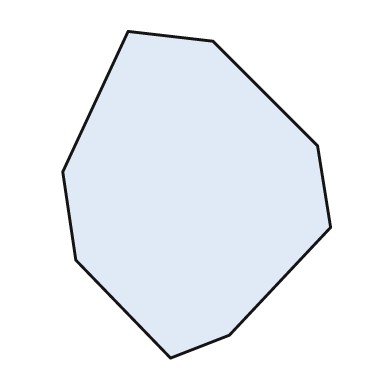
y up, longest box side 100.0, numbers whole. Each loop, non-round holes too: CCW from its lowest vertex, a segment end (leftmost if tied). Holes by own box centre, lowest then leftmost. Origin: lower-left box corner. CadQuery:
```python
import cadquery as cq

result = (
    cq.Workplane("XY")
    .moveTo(33.0, 0.0)
    .lineTo(51.0, 7.0)
    .lineTo(82.0, 40.0)
    .lineTo(78.0, 65.0)
    .lineTo(46.0, 97.0)
    .lineTo(20.0, 100.0)
    .lineTo(0.0, 57.0)
    .lineTo(4.0, 30.0)
    .close()
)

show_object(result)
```